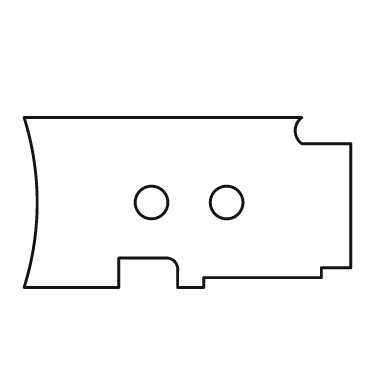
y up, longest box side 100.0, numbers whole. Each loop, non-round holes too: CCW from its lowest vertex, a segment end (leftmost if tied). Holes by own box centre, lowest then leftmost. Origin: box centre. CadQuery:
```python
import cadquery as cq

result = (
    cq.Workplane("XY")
    .moveTo(-50.0, -26.0)
    .lineTo(-21.0, -26.0)
    .lineTo(-21.0, -17.0)
    .lineTo(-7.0, -17.0)
    .threePointArc((-4.0, -18.0), (-3.0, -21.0))
    .lineTo(-3.0, -26.0)
    .lineTo(5.0, -26.0)
    .lineTo(5.0, -23.0)
    .lineTo(41.0, -23.0)
    .lineTo(41.0, -20.0)
    .lineTo(50.0, -20.0)
    .lineTo(50.0, 18.0)
    .lineTo(35.0, 18.0)
    .threePointArc((33.0, 22.0), (35.0, 26.0))
    .lineTo(-50.0, 26.0)
    .threePointArc((-46.0, 0.0), (-50.0, -26.0))
    .close()
    .moveTo(-11.0, 0.0)
    .circle(5.0)
    .moveTo(12.0, 0.0)
    .circle(5.0)
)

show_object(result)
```